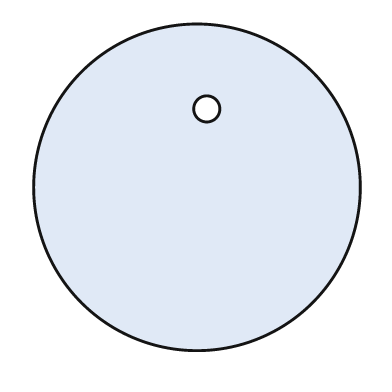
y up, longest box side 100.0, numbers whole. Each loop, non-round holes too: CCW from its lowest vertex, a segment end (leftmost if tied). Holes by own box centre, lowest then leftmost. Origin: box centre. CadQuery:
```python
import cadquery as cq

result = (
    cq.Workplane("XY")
    .moveTo(0.0, 0.0)
    .circle(50.0)
    .moveTo(3.0, 24.0)
    .circle(4.0)
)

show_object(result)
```